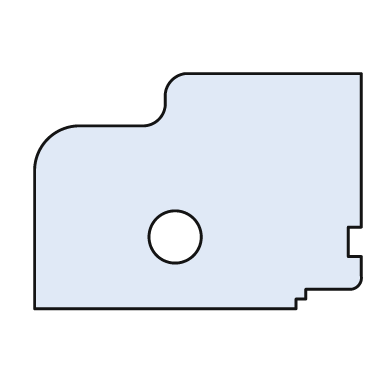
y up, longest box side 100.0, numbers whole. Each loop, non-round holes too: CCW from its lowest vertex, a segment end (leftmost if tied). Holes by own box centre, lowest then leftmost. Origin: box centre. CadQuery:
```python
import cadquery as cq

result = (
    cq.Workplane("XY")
    .moveTo(-50.0, -36.0)
    .lineTo(30.0, -36.0)
    .lineTo(30.0, -33.0)
    .lineTo(33.0, -33.0)
    .lineTo(33.0, -30.0)
    .lineTo(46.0, -30.0)
    .threePointArc((49.0, -29.0), (50.0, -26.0))
    .lineTo(50.0, -20.0)
    .lineTo(46.0, -20.0)
    .lineTo(46.0, -11.0)
    .lineTo(50.0, -11.0)
    .lineTo(50.0, 36.0)
    .lineTo(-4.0, 36.0)
    .threePointArc((-8.0, 34.0), (-10.0, 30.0))
    .lineTo(-10.0, 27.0)
    .threePointArc((-12.0, 22.0), (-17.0, 20.0))
    .lineTo(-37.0, 20.0)
    .threePointArc((-46.0, 16.0), (-50.0, 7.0))
    .close()
    .moveTo(-7.0, -14.0)
    .circle(8.0)
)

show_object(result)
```